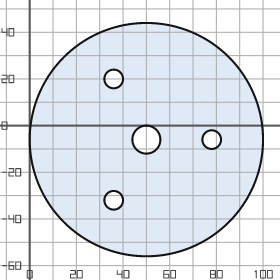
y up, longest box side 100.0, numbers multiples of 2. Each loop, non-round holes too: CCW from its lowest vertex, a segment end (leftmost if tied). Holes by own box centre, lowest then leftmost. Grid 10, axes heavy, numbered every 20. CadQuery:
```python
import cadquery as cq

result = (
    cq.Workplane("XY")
    .moveTo(50.0, -6.0)
    .circle(50.0)
    .moveTo(36.0, -32.0)
    .circle(4.0)
    .moveTo(50.0, -6.0)
    .circle(6.0)
    .moveTo(78.0, -6.0)
    .circle(4.0)
    .moveTo(36.0, 20.0)
    .circle(4.0)
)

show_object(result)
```